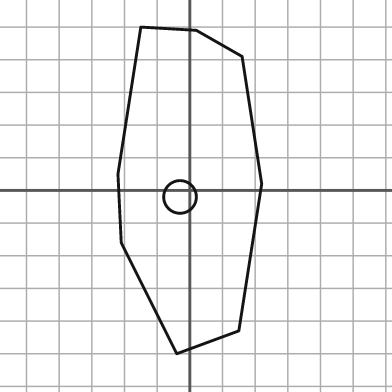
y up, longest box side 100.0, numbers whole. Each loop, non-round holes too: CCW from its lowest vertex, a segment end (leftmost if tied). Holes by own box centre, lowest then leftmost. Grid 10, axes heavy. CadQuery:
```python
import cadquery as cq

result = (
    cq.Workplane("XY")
    .moveTo(-4.0, -50.0)
    .lineTo(15.0, -43.0)
    .lineTo(22.0, 2.0)
    .lineTo(16.0, 41.0)
    .lineTo(2.0, 49.0)
    .lineTo(-15.0, 50.0)
    .lineTo(-22.0, 5.0)
    .lineTo(-21.0, -16.0)
    .close()
    .moveTo(-3.0, -2.0)
    .circle(5.0)
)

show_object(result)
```